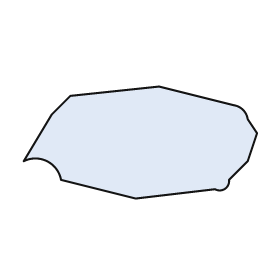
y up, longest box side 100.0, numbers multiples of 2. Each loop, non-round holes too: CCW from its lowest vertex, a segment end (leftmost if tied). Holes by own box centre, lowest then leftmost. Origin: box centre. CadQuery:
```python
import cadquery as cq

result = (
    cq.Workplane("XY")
    .moveTo(-2.0, -24.0)
    .lineTo(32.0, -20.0)
    .threePointArc((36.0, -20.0), (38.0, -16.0))
    .lineTo(46.0, -8.0)
    .lineTo(50.0, 4.0)
    .lineTo(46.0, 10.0)
    .threePointArc((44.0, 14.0), (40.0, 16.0))
    .lineTo(8.0, 24.0)
    .lineTo(-30.0, 20.0)
    .lineTo(-38.0, 12.0)
    .lineTo(-50.0, -8.0)
    .threePointArc((-40.0, -8.0), (-34.0, -16.0))
    .close()
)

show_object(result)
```